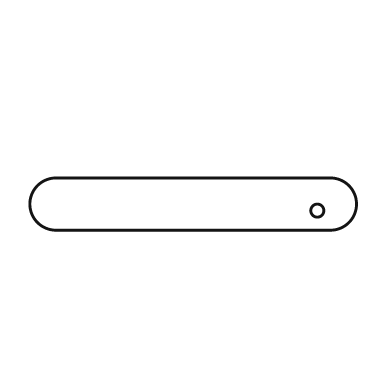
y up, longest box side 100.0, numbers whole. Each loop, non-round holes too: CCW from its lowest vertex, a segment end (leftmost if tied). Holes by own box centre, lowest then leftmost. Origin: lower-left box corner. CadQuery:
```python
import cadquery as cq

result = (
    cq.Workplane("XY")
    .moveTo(8.0, 0.0)
    .lineTo(92.0, 0.0)
    .threePointArc((100.0, 8.0), (92.0, 16.0))
    .lineTo(8.0, 16.0)
    .threePointArc((0.0, 8.0), (8.0, 0.0))
    .close()
    .moveTo(88.0, 6.0)
    .circle(2.0)
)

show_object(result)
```